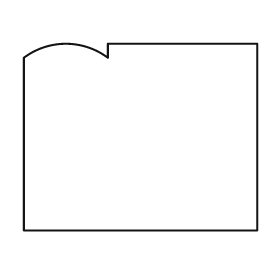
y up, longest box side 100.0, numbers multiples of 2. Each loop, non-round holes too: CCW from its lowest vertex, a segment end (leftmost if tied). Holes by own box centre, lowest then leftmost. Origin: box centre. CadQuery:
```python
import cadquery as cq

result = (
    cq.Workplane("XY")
    .moveTo(-50.0, -40.0)
    .lineTo(50.0, -40.0)
    .lineTo(50.0, 40.0)
    .lineTo(-14.0, 40.0)
    .lineTo(-14.0, 34.0)
    .threePointArc((-32.0, 40.0), (-50.0, 34.0))
    .close()
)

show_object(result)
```